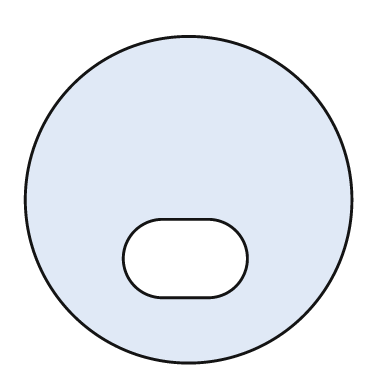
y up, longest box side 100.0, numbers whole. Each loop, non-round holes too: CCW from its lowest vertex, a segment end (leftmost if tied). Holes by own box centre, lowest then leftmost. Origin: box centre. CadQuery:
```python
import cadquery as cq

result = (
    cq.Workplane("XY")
    .moveTo(0.0, 0.0)
    .circle(50.0)
    .moveTo(-8.0, -30.0)
    .lineTo(6.0, -30.0)
    .threePointArc((18.0, -18.0), (6.0, -6.0))
    .lineTo(-8.0, -6.0)
    .threePointArc((-20.0, -18.0), (-8.0, -30.0))
    .close()
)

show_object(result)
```